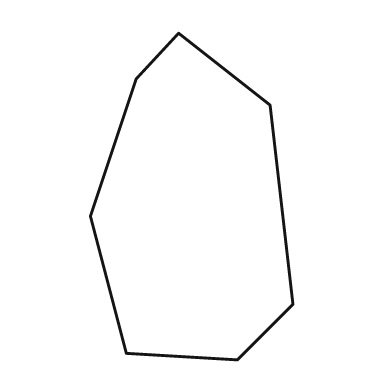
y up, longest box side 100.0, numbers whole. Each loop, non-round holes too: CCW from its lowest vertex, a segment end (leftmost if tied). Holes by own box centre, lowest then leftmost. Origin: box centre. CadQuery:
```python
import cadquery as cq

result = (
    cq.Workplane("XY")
    .moveTo(14.0, -50.0)
    .lineTo(31.0, -33.0)
    .lineTo(24.0, 28.0)
    .lineTo(-4.0, 50.0)
    .lineTo(-17.0, 36.0)
    .lineTo(-31.0, -6.0)
    .lineTo(-20.0, -48.0)
    .close()
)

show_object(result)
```